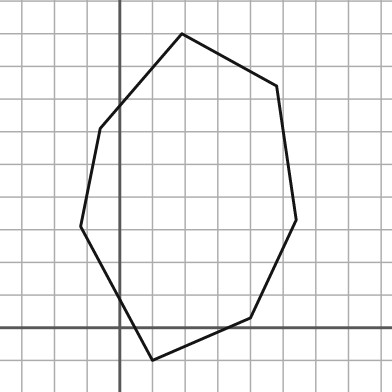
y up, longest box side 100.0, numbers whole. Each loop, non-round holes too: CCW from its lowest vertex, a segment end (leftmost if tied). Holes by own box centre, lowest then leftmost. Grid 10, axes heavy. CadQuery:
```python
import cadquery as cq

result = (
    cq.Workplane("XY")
    .moveTo(10.0, -10.0)
    .lineTo(40.0, 3.0)
    .lineTo(54.0, 33.0)
    .lineTo(48.0, 74.0)
    .lineTo(19.0, 90.0)
    .lineTo(-6.0, 61.0)
    .lineTo(-12.0, 31.0)
    .close()
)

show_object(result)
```